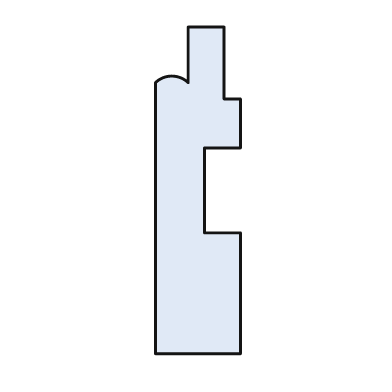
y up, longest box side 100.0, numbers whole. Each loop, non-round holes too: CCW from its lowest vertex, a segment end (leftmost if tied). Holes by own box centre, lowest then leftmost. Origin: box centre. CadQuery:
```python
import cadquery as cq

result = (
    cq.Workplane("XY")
    .moveTo(-13.0, -50.0)
    .lineTo(13.0, -50.0)
    .lineTo(13.0, -13.0)
    .lineTo(2.0, -13.0)
    .lineTo(2.0, 13.0)
    .lineTo(13.0, 13.0)
    .lineTo(13.0, 28.0)
    .lineTo(8.0, 28.0)
    .lineTo(8.0, 50.0)
    .lineTo(-3.0, 50.0)
    .lineTo(-3.0, 33.0)
    .threePointArc((-8.0, 35.0), (-13.0, 33.0))
    .close()
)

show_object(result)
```